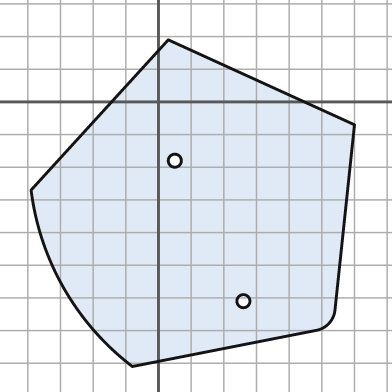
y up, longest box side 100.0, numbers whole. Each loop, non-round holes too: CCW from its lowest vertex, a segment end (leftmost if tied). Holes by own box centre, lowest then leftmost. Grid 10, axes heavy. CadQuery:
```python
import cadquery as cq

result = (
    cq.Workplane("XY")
    .moveTo(-8.0, -81.0)
    .lineTo(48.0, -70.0)
    .threePointArc((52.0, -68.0), (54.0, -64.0))
    .lineTo(60.0, -7.0)
    .lineTo(3.0, 19.0)
    .lineTo(-39.0, -27.0)
    .threePointArc((-29.0, -57.0), (-8.0, -81.0))
    .close()
    .moveTo(26.0, -61.0)
    .circle(2.0)
    .moveTo(5.0, -18.0)
    .circle(2.0)
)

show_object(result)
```